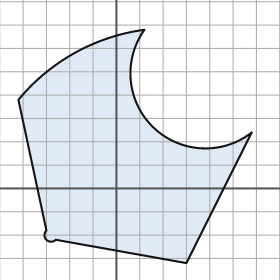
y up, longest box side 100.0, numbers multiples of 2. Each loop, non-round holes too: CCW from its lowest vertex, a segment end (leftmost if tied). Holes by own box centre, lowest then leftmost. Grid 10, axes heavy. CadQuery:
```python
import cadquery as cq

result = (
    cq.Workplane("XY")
    .moveTo(30.0, -32.0)
    .lineTo(58.0, 24.0)
    .threePointArc((16.0, 26.0), (12.0, 68.0))
    .threePointArc((-18.0, 58.0), (-42.0, 38.0))
    .lineTo(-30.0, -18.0)
    .threePointArc((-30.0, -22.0), (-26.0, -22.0))
    .close()
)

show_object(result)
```